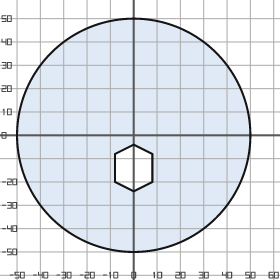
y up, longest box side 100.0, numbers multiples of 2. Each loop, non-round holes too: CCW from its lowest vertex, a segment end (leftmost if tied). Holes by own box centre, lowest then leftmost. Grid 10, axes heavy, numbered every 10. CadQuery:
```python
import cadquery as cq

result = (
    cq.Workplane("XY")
    .moveTo(0.0, 0.0)
    .circle(50.0)
    .moveTo(0.0, -24.0)
    .lineTo(8.0, -20.0)
    .lineTo(8.0, -8.0)
    .lineTo(0.0, -4.0)
    .lineTo(-8.0, -8.0)
    .lineTo(-8.0, -20.0)
    .close()
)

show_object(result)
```